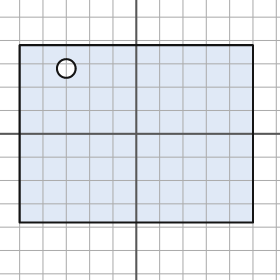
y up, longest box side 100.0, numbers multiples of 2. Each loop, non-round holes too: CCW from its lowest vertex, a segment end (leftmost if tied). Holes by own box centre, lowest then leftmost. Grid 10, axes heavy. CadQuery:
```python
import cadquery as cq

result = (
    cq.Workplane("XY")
    .moveTo(-50.0, -38.0)
    .lineTo(50.0, -38.0)
    .lineTo(50.0, 38.0)
    .lineTo(-50.0, 38.0)
    .close()
    .moveTo(-30.0, 28.0)
    .circle(4.0)
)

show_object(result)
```